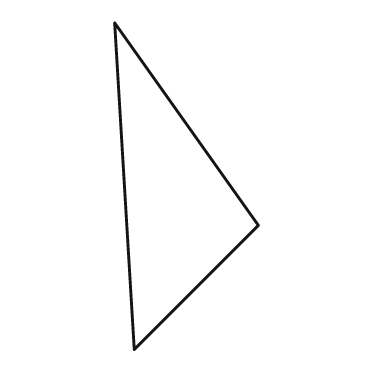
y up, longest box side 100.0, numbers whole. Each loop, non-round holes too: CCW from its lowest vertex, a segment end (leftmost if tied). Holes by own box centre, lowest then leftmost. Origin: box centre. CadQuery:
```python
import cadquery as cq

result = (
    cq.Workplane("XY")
    .moveTo(-16.0, -50.0)
    .lineTo(22.0, -12.0)
    .lineTo(-22.0, 50.0)
    .close()
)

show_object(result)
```